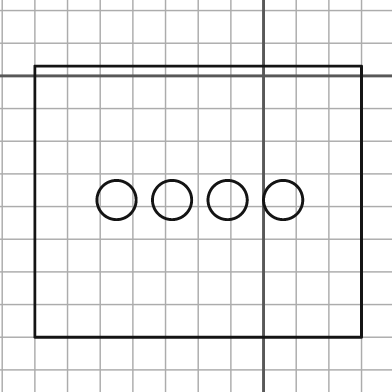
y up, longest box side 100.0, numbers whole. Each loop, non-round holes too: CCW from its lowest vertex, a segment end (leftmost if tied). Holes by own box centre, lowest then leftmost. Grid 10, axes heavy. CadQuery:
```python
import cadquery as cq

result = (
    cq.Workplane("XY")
    .moveTo(-70.0, -80.0)
    .lineTo(30.0, -80.0)
    .lineTo(30.0, 3.0)
    .lineTo(-70.0, 3.0)
    .close()
    .moveTo(-45.0, -38.0)
    .circle(6.0)
    .moveTo(-28.0, -38.0)
    .circle(6.0)
    .moveTo(-11.0, -38.0)
    .circle(6.0)
    .moveTo(6.0, -38.0)
    .circle(6.0)
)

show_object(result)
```